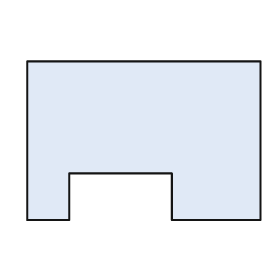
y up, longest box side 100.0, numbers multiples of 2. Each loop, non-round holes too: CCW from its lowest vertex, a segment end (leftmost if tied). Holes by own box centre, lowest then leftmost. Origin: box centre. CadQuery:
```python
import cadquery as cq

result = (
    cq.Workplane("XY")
    .moveTo(-50.0, -34.0)
    .lineTo(-32.0, -34.0)
    .lineTo(-32.0, -14.0)
    .lineTo(12.0, -14.0)
    .lineTo(12.0, -34.0)
    .lineTo(50.0, -34.0)
    .lineTo(50.0, 34.0)
    .lineTo(-50.0, 34.0)
    .close()
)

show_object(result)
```